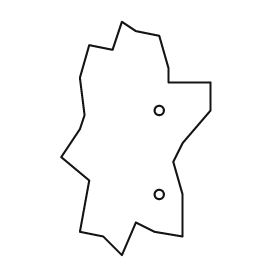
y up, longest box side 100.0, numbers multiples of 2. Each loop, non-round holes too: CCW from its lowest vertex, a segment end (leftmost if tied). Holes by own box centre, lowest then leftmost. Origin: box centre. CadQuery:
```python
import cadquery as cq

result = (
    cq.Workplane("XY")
    .moveTo(-6.0, -50.0)
    .lineTo(0.0, -36.0)
    .lineTo(8.0, -40.0)
    .lineTo(20.0, -42.0)
    .lineTo(20.0, -24.0)
    .lineTo(16.0, -10.0)
    .lineTo(20.0, -2.0)
    .lineTo(32.0, 12.0)
    .lineTo(32.0, 24.0)
    .lineTo(14.0, 24.0)
    .lineTo(14.0, 30.0)
    .lineTo(10.0, 44.0)
    .lineTo(0.0, 46.0)
    .lineTo(-6.0, 50.0)
    .lineTo(-10.0, 38.0)
    .lineTo(-20.0, 40.0)
    .lineTo(-24.0, 26.0)
    .lineTo(-22.0, 10.0)
    .lineTo(-24.0, 4.0)
    .lineTo(-32.0, -8.0)
    .lineTo(-20.0, -18.0)
    .lineTo(-24.0, -40.0)
    .lineTo(-14.0, -42.0)
    .close()
    .moveTo(10.0, -24.0)
    .circle(2.0)
    .moveTo(10.0, 12.0)
    .circle(2.0)
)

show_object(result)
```